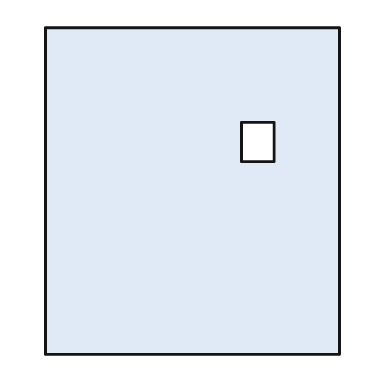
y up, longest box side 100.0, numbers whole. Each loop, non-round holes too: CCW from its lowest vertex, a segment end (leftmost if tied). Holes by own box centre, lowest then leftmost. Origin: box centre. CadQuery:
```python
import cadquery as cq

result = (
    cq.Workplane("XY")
    .moveTo(-45.0, -50.0)
    .lineTo(45.0, -50.0)
    .lineTo(45.0, 50.0)
    .lineTo(-45.0, 50.0)
    .close()
    .moveTo(15.0, 9.0)
    .lineTo(25.0, 9.0)
    .lineTo(25.0, 21.0)
    .lineTo(15.0, 21.0)
    .close()
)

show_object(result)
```